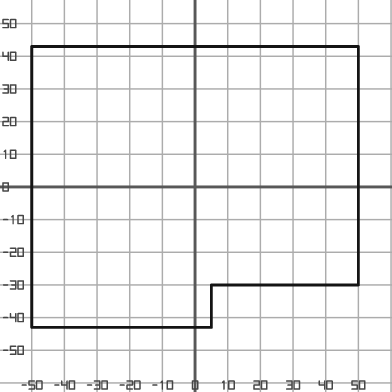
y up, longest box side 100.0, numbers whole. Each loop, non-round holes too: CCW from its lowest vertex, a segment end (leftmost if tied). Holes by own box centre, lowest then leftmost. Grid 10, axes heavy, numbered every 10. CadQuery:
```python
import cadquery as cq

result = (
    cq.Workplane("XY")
    .moveTo(-50.0, -43.0)
    .lineTo(5.0, -43.0)
    .lineTo(5.0, -30.0)
    .lineTo(50.0, -30.0)
    .lineTo(50.0, 43.0)
    .lineTo(-50.0, 43.0)
    .close()
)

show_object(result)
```